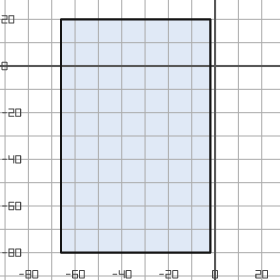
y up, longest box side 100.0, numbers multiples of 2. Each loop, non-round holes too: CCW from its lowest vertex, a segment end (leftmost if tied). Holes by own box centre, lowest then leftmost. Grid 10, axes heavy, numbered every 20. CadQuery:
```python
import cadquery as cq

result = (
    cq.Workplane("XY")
    .moveTo(-66.0, -80.0)
    .lineTo(-2.0, -80.0)
    .lineTo(-2.0, 20.0)
    .lineTo(-66.0, 20.0)
    .close()
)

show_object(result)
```